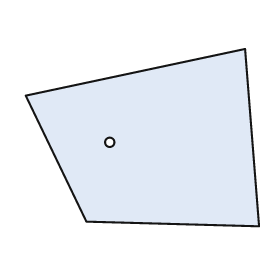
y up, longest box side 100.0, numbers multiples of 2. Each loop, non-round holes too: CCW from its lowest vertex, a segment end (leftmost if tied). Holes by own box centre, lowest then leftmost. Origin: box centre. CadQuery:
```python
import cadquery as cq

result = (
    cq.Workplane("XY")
    .moveTo(50.0, -38.0)
    .lineTo(44.0, 38.0)
    .lineTo(-50.0, 18.0)
    .lineTo(-24.0, -36.0)
    .close()
    .moveTo(-14.0, -2.0)
    .circle(2.0)
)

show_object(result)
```